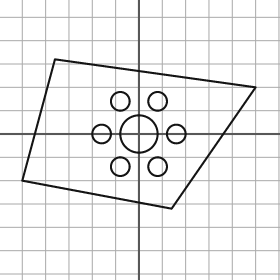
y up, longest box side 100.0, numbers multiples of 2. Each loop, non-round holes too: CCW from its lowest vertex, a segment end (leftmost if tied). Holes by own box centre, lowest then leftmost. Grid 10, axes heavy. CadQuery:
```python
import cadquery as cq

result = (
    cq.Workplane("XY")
    .moveTo(14.0, -32.0)
    .lineTo(50.0, 20.0)
    .lineTo(-36.0, 32.0)
    .lineTo(-50.0, -20.0)
    .close()
    .moveTo(-8.0, -14.0)
    .circle(4.0)
    .moveTo(8.0, -14.0)
    .circle(4.0)
    .moveTo(-16.0, 0.0)
    .circle(4.0)
    .moveTo(0.0, 0.0)
    .circle(8.0)
    .moveTo(16.0, 0.0)
    .circle(4.0)
    .moveTo(-8.0, 14.0)
    .circle(4.0)
    .moveTo(8.0, 14.0)
    .circle(4.0)
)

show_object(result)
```